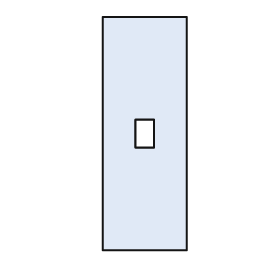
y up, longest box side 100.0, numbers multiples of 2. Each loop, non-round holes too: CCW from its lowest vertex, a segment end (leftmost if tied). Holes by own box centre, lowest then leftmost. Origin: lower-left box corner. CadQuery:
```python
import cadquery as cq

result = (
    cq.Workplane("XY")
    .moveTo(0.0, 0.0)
    .lineTo(36.0, 0.0)
    .lineTo(36.0, 100.0)
    .lineTo(0.0, 100.0)
    .close()
    .moveTo(14.0, 44.0)
    .lineTo(22.0, 44.0)
    .lineTo(22.0, 56.0)
    .lineTo(14.0, 56.0)
    .close()
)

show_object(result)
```